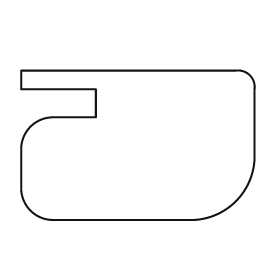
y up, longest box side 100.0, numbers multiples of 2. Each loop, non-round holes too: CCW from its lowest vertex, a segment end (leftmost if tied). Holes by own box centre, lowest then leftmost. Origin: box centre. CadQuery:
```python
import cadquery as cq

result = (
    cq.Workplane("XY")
    .moveTo(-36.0, -32.0)
    .lineTo(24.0, -32.0)
    .threePointArc((42.0, -24.0), (50.0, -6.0))
    .lineTo(50.0, 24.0)
    .threePointArc((48.0, 30.0), (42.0, 32.0))
    .lineTo(-50.0, 32.0)
    .lineTo(-50.0, 24.0)
    .lineTo(-18.0, 24.0)
    .lineTo(-18.0, 12.0)
    .lineTo(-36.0, 12.0)
    .threePointArc((-46.0, 8.0), (-50.0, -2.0))
    .lineTo(-50.0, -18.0)
    .threePointArc((-46.0, -28.0), (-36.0, -32.0))
    .close()
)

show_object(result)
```